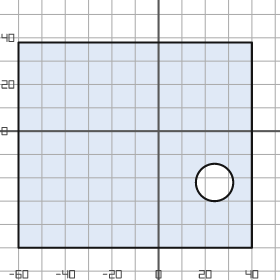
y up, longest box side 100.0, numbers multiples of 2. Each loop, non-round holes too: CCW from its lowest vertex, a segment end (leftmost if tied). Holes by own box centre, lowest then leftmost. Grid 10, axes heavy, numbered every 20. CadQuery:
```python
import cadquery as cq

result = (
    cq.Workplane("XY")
    .moveTo(-60.0, -50.0)
    .lineTo(40.0, -50.0)
    .lineTo(40.0, 38.0)
    .lineTo(-60.0, 38.0)
    .close()
    .moveTo(24.0, -22.0)
    .circle(8.0)
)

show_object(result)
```